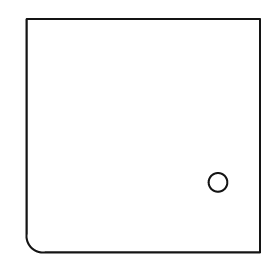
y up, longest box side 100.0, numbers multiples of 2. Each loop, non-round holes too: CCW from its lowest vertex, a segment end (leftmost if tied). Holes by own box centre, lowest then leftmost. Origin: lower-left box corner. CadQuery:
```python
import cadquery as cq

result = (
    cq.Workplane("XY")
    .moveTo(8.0, 0.0)
    .lineTo(100.0, 0.0)
    .lineTo(100.0, 100.0)
    .lineTo(0.0, 100.0)
    .lineTo(0.0, 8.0)
    .threePointArc((2.0, 2.0), (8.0, 0.0))
    .close()
    .moveTo(82.0, 30.0)
    .circle(4.0)
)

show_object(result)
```